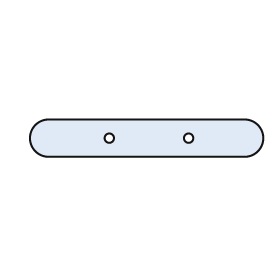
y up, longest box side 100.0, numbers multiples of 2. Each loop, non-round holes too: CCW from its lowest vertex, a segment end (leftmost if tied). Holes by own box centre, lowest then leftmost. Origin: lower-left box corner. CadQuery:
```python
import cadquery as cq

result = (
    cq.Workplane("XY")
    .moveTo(8.0, 0.0)
    .lineTo(92.0, 0.0)
    .threePointArc((100.0, 8.0), (92.0, 16.0))
    .lineTo(8.0, 16.0)
    .threePointArc((0.0, 8.0), (8.0, 0.0))
    .close()
    .moveTo(34.0, 8.0)
    .circle(2.0)
    .moveTo(68.0, 8.0)
    .circle(2.0)
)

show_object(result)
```